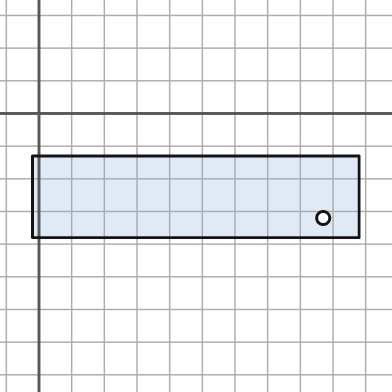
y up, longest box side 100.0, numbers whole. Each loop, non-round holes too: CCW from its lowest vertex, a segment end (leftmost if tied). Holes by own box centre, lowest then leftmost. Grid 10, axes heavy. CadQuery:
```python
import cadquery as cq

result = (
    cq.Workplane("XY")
    .moveTo(-2.0, -38.0)
    .lineTo(98.0, -38.0)
    .lineTo(98.0, -13.0)
    .lineTo(-2.0, -13.0)
    .close()
    .moveTo(87.0, -32.0)
    .circle(2.0)
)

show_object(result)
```